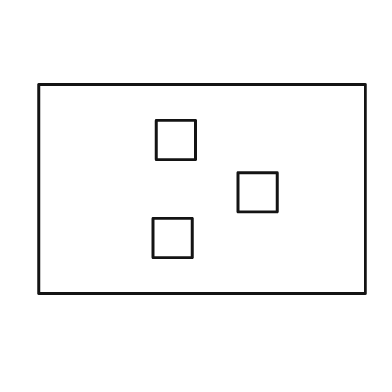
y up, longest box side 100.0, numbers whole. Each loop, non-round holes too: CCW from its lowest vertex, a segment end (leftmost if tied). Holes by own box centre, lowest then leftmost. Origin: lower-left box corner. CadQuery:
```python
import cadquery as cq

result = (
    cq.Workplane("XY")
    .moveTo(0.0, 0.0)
    .lineTo(100.0, 0.0)
    .lineTo(100.0, 64.0)
    .lineTo(0.0, 64.0)
    .close()
    .moveTo(35.0, 11.0)
    .lineTo(47.0, 11.0)
    .lineTo(47.0, 23.0)
    .lineTo(35.0, 23.0)
    .close()
    .moveTo(61.0, 25.0)
    .lineTo(73.0, 25.0)
    .lineTo(73.0, 37.0)
    .lineTo(61.0, 37.0)
    .close()
    .moveTo(36.0, 41.0)
    .lineTo(48.0, 41.0)
    .lineTo(48.0, 53.0)
    .lineTo(36.0, 53.0)
    .close()
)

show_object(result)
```